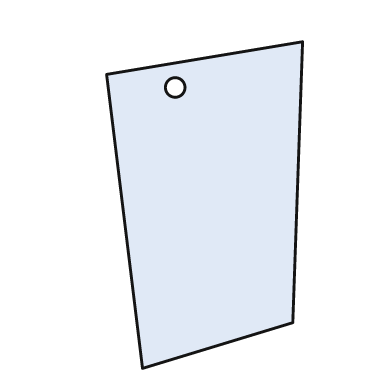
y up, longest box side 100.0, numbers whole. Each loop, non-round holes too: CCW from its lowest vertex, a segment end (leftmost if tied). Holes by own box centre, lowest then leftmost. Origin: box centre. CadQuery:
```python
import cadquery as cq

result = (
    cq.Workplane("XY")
    .moveTo(-19.0, -50.0)
    .lineTo(27.0, -36.0)
    .lineTo(30.0, 50.0)
    .lineTo(-30.0, 40.0)
    .close()
    .moveTo(-9.0, 36.0)
    .circle(3.0)
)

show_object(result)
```